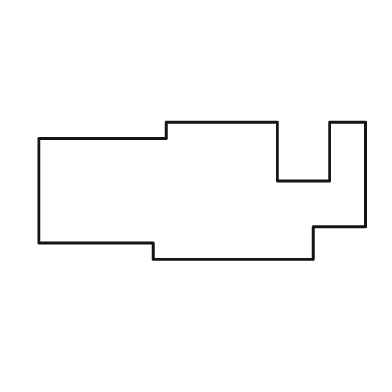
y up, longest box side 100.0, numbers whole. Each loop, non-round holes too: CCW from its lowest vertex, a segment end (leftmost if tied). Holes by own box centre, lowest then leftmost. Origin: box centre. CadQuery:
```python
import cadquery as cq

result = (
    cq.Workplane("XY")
    .moveTo(-15.0, -21.0)
    .lineTo(34.0, -21.0)
    .lineTo(34.0, -11.0)
    .lineTo(50.0, -11.0)
    .lineTo(50.0, 21.0)
    .lineTo(39.0, 21.0)
    .lineTo(39.0, 3.0)
    .lineTo(23.0, 3.0)
    .lineTo(23.0, 21.0)
    .lineTo(-11.0, 21.0)
    .lineTo(-11.0, 16.0)
    .lineTo(-50.0, 16.0)
    .lineTo(-50.0, -16.0)
    .lineTo(-15.0, -16.0)
    .close()
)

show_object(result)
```